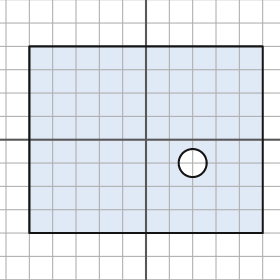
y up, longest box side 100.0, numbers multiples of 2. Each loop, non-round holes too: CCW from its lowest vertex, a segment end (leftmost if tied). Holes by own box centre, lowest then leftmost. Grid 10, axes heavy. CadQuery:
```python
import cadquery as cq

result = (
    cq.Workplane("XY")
    .moveTo(-50.0, -40.0)
    .lineTo(50.0, -40.0)
    .lineTo(50.0, 40.0)
    .lineTo(-50.0, 40.0)
    .close()
    .moveTo(20.0, -10.0)
    .circle(6.0)
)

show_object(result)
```